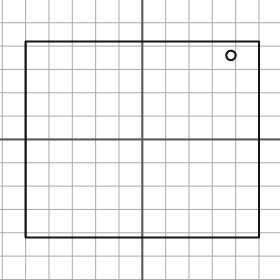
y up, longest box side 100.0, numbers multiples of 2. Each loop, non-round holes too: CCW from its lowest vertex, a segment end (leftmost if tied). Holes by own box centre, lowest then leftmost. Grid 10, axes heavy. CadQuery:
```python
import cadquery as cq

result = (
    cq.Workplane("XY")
    .moveTo(-50.0, -42.0)
    .lineTo(50.0, -42.0)
    .lineTo(50.0, 42.0)
    .lineTo(-50.0, 42.0)
    .close()
    .moveTo(38.0, 36.0)
    .circle(2.0)
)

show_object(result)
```